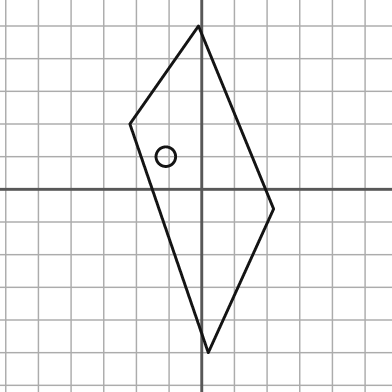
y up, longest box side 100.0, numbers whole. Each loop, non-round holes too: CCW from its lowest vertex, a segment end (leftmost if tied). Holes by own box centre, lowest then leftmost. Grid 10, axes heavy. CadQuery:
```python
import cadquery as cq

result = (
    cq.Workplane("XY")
    .moveTo(2.0, -50.0)
    .lineTo(22.0, -6.0)
    .lineTo(-1.0, 50.0)
    .lineTo(-22.0, 20.0)
    .close()
    .moveTo(-11.0, 10.0)
    .circle(3.0)
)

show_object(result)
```